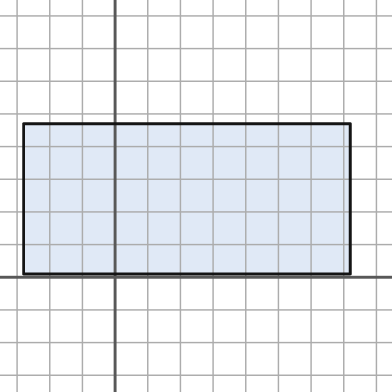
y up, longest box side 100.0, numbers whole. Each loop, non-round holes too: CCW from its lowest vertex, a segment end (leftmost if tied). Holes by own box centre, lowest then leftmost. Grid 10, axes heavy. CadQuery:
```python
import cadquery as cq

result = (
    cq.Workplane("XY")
    .moveTo(-28.0, 1.0)
    .lineTo(72.0, 1.0)
    .lineTo(72.0, 47.0)
    .lineTo(-28.0, 47.0)
    .close()
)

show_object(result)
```